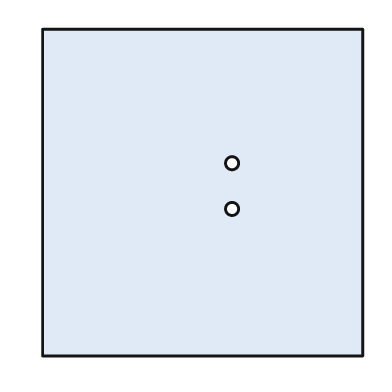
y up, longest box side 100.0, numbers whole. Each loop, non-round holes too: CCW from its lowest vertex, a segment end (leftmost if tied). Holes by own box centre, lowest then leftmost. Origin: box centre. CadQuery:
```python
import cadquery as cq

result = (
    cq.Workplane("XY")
    .moveTo(-49.0, -50.0)
    .lineTo(49.0, -50.0)
    .lineTo(49.0, 50.0)
    .lineTo(-49.0, 50.0)
    .close()
    .moveTo(9.0, -5.0)
    .circle(2.0)
    .moveTo(9.0, 9.0)
    .circle(2.0)
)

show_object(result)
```